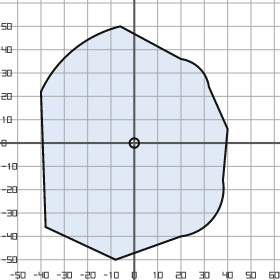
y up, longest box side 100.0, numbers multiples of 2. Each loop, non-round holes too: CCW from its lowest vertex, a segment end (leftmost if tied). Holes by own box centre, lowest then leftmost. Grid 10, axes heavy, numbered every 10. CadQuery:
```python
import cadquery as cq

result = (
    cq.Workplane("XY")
    .moveTo(-8.0, -50.0)
    .lineTo(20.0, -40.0)
    .threePointArc((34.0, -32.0), (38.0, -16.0))
    .lineTo(40.0, 6.0)
    .lineTo(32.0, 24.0)
    .threePointArc((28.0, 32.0), (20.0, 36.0))
    .lineTo(-6.0, 50.0)
    .threePointArc((-26.0, 40.0), (-40.0, 22.0))
    .lineTo(-38.0, -36.0)
    .close()
    .moveTo(0.0, 0.0)
    .circle(2.0)
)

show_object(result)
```